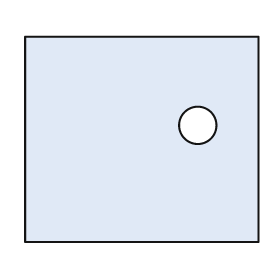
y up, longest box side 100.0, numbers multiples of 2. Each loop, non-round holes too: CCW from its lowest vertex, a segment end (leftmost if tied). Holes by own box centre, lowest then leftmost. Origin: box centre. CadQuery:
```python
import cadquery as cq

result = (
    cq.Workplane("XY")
    .moveTo(-50.0, -44.0)
    .lineTo(50.0, -44.0)
    .lineTo(50.0, 44.0)
    .lineTo(-50.0, 44.0)
    .close()
    .moveTo(24.0, 6.0)
    .circle(8.0)
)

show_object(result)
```